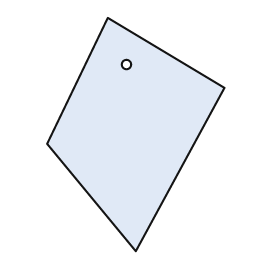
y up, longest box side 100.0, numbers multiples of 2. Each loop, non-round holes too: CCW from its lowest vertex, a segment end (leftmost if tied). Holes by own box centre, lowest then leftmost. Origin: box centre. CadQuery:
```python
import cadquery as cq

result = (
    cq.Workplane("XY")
    .moveTo(0.0, -50.0)
    .lineTo(38.0, 20.0)
    .lineTo(-12.0, 50.0)
    .lineTo(-38.0, -4.0)
    .close()
    .moveTo(-4.0, 30.0)
    .circle(2.0)
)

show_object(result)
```